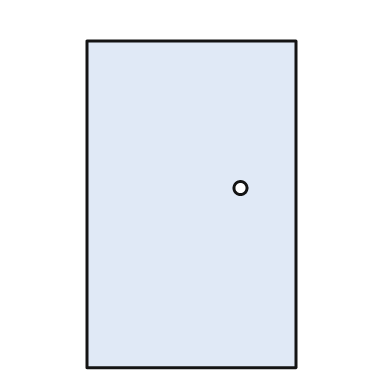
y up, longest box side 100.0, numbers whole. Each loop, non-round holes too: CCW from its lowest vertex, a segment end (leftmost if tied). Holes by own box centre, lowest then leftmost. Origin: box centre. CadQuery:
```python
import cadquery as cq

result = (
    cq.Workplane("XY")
    .moveTo(-32.0, -50.0)
    .lineTo(32.0, -50.0)
    .lineTo(32.0, 50.0)
    .lineTo(-32.0, 50.0)
    .close()
    .moveTo(15.0, 5.0)
    .circle(2.0)
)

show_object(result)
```